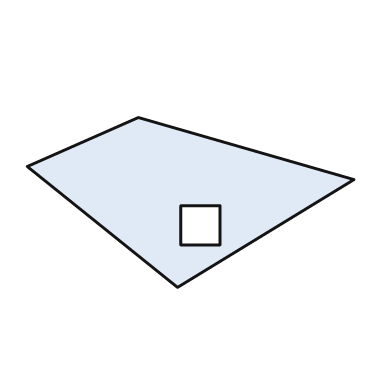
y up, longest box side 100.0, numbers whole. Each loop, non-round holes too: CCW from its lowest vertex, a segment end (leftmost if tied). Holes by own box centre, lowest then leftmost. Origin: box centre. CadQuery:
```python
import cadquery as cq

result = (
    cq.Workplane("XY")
    .moveTo(-4.0, -26.0)
    .lineTo(50.0, 7.0)
    .lineTo(-16.0, 26.0)
    .lineTo(-50.0, 11.0)
    .close()
    .moveTo(-3.0, -13.0)
    .lineTo(9.0, -13.0)
    .lineTo(9.0, -1.0)
    .lineTo(-3.0, -1.0)
    .close()
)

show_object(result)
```